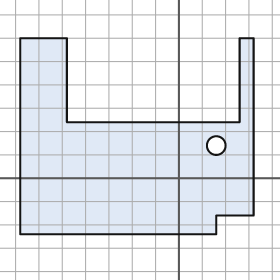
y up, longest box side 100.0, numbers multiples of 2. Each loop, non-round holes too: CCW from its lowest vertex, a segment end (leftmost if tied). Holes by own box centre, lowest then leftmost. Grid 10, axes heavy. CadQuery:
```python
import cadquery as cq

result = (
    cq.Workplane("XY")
    .moveTo(-68.0, -24.0)
    .lineTo(16.0, -24.0)
    .lineTo(16.0, -16.0)
    .lineTo(32.0, -16.0)
    .lineTo(32.0, 60.0)
    .lineTo(26.0, 60.0)
    .lineTo(26.0, 24.0)
    .lineTo(-48.0, 24.0)
    .lineTo(-48.0, 60.0)
    .lineTo(-68.0, 60.0)
    .close()
    .moveTo(16.0, 14.0)
    .circle(4.0)
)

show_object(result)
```